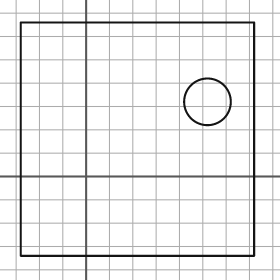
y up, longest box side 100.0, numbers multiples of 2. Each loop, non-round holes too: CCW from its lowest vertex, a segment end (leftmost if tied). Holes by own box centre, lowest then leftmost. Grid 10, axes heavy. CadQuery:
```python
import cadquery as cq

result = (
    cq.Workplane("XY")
    .moveTo(-28.0, -34.0)
    .lineTo(72.0, -34.0)
    .lineTo(72.0, 66.0)
    .lineTo(-28.0, 66.0)
    .close()
    .moveTo(52.0, 32.0)
    .circle(10.0)
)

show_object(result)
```